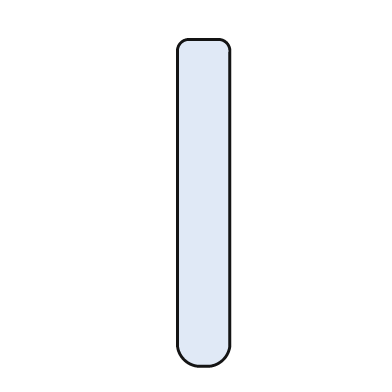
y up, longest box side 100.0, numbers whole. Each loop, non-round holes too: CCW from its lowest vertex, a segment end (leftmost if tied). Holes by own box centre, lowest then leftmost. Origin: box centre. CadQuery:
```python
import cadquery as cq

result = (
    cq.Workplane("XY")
    .moveTo(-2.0, -50.0)
    .lineTo(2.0, -50.0)
    .threePointArc((6.0, -48.0), (8.0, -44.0))
    .lineTo(8.0, 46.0)
    .threePointArc((7.0, 49.0), (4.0, 50.0))
    .lineTo(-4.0, 50.0)
    .threePointArc((-7.0, 49.0), (-8.0, 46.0))
    .lineTo(-8.0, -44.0)
    .threePointArc((-6.0, -48.0), (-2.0, -50.0))
    .close()
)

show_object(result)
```